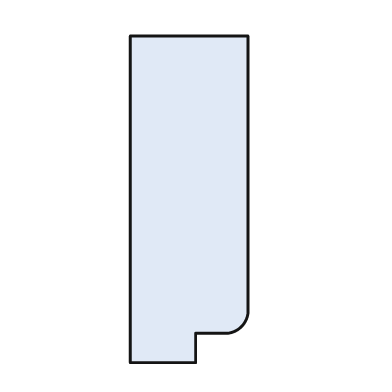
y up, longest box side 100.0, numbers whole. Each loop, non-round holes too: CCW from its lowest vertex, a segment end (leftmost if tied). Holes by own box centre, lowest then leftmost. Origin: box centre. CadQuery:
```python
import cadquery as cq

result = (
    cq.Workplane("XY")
    .moveTo(-18.0, -50.0)
    .lineTo(2.0, -50.0)
    .lineTo(2.0, -41.0)
    .lineTo(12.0, -41.0)
    .threePointArc((16.0, -39.0), (18.0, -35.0))
    .lineTo(18.0, 50.0)
    .lineTo(-18.0, 50.0)
    .close()
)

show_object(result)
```